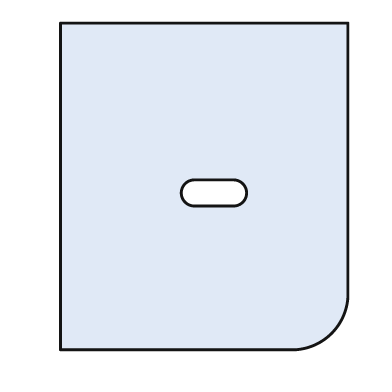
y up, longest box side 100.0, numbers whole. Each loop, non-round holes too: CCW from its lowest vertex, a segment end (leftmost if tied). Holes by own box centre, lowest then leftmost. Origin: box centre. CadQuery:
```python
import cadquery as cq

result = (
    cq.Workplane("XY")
    .moveTo(-44.0, -50.0)
    .lineTo(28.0, -50.0)
    .threePointArc((39.0, -45.0), (44.0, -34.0))
    .lineTo(44.0, 50.0)
    .lineTo(-44.0, 50.0)
    .close()
    .moveTo(-3.0, -6.0)
    .lineTo(9.0, -6.0)
    .threePointArc((13.0, -2.0), (9.0, 2.0))
    .lineTo(-3.0, 2.0)
    .threePointArc((-7.0, -2.0), (-3.0, -6.0))
    .close()
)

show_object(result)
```